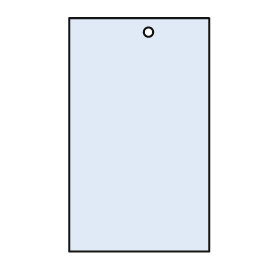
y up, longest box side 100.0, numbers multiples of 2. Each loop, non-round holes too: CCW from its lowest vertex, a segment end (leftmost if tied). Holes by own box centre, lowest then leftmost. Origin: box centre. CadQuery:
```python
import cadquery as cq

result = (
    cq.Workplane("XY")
    .moveTo(-30.0, -50.0)
    .lineTo(30.0, -50.0)
    .lineTo(30.0, 50.0)
    .lineTo(-30.0, 50.0)
    .close()
    .moveTo(4.0, 44.0)
    .circle(2.0)
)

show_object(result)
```